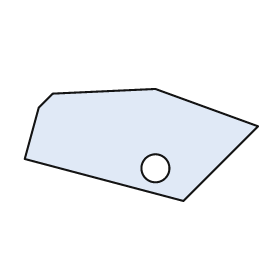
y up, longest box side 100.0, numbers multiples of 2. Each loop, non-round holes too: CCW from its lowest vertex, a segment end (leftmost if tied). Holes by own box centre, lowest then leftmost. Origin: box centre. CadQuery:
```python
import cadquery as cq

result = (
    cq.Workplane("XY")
    .moveTo(18.0, -24.0)
    .lineTo(50.0, 8.0)
    .lineTo(6.0, 24.0)
    .lineTo(-38.0, 22.0)
    .lineTo(-44.0, 16.0)
    .lineTo(-50.0, -6.0)
    .close()
    .moveTo(6.0, -10.0)
    .circle(6.0)
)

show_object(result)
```